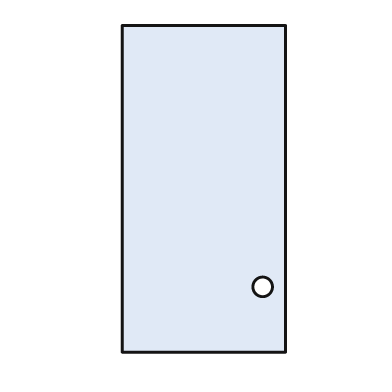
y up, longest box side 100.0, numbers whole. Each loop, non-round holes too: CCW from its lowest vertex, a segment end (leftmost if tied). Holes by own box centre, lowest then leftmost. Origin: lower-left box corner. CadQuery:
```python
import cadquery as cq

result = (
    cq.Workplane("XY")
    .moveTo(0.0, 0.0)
    .lineTo(50.0, 0.0)
    .lineTo(50.0, 100.0)
    .lineTo(0.0, 100.0)
    .close()
    .moveTo(43.0, 20.0)
    .circle(3.0)
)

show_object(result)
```